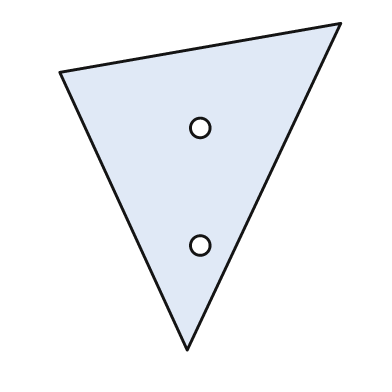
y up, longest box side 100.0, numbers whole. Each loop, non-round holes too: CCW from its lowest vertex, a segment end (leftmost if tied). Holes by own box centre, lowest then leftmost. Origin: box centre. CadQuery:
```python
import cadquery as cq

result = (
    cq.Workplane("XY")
    .moveTo(-4.0, -50.0)
    .lineTo(43.0, 50.0)
    .lineTo(-43.0, 35.0)
    .close()
    .moveTo(0.0, -18.0)
    .circle(3.0)
    .moveTo(0.0, 18.0)
    .circle(3.0)
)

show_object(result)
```